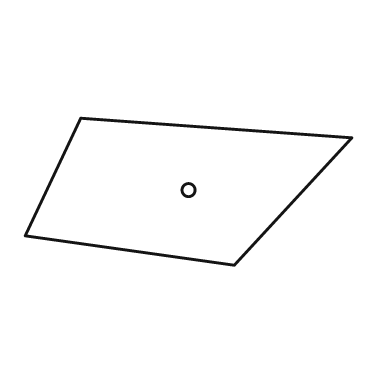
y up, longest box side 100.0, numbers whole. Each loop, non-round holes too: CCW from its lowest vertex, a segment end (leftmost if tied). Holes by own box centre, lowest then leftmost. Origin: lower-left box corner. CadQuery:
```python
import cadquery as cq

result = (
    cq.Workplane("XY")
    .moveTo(64.0, 0.0)
    .lineTo(100.0, 39.0)
    .lineTo(17.0, 45.0)
    .lineTo(0.0, 9.0)
    .close()
    .moveTo(50.0, 23.0)
    .circle(2.0)
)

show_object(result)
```